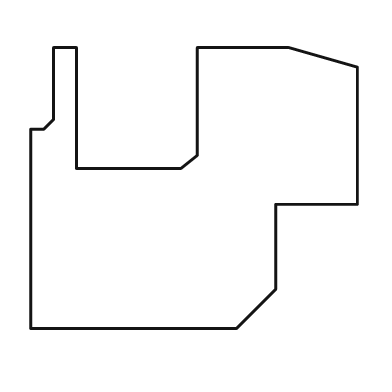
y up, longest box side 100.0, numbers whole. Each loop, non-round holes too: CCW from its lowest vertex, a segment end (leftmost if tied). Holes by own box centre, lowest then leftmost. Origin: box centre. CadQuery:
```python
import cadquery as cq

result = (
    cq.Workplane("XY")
    .moveTo(-50.0, -43.0)
    .lineTo(13.0, -43.0)
    .lineTo(25.0, -31.0)
    .lineTo(25.0, -5.0)
    .lineTo(50.0, -5.0)
    .lineTo(50.0, 37.0)
    .lineTo(29.0, 43.0)
    .lineTo(1.0, 43.0)
    .lineTo(1.0, 10.0)
    .lineTo(-4.0, 6.0)
    .lineTo(-36.0, 6.0)
    .lineTo(-36.0, 43.0)
    .lineTo(-43.0, 43.0)
    .lineTo(-43.0, 21.0)
    .lineTo(-46.0, 18.0)
    .lineTo(-50.0, 18.0)
    .close()
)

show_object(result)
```